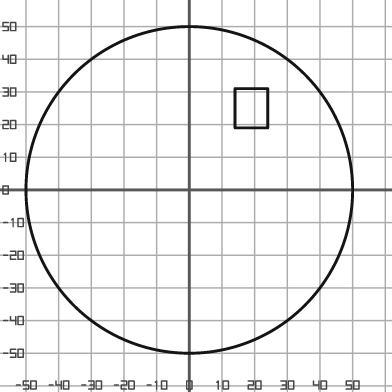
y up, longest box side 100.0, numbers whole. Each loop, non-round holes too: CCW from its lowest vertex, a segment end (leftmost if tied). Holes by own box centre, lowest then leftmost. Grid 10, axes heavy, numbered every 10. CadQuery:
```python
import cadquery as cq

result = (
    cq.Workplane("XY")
    .moveTo(0.0, 0.0)
    .circle(50.0)
    .moveTo(14.0, 19.0)
    .lineTo(24.0, 19.0)
    .lineTo(24.0, 31.0)
    .lineTo(14.0, 31.0)
    .close()
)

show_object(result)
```